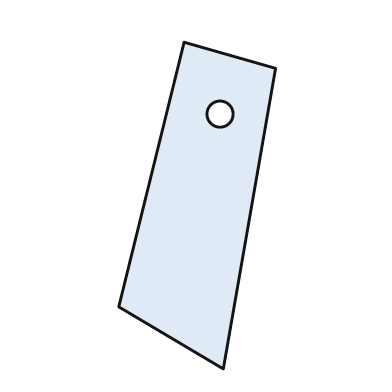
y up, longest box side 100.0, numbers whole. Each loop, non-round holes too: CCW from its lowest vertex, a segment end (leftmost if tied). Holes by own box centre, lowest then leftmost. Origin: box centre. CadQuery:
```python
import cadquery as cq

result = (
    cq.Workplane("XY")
    .moveTo(8.0, -50.0)
    .lineTo(24.0, 42.0)
    .lineTo(-4.0, 50.0)
    .lineTo(-24.0, -31.0)
    .close()
    .moveTo(7.0, 28.0)
    .circle(4.0)
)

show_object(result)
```